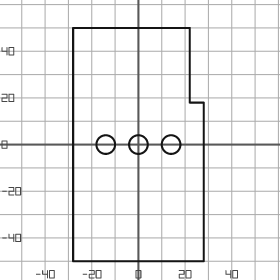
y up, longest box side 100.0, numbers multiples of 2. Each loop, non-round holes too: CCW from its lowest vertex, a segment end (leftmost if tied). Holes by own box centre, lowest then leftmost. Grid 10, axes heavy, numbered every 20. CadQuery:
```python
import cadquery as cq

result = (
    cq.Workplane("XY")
    .moveTo(-28.0, -50.0)
    .lineTo(28.0, -50.0)
    .lineTo(28.0, 18.0)
    .lineTo(22.0, 18.0)
    .lineTo(22.0, 50.0)
    .lineTo(-28.0, 50.0)
    .close()
    .moveTo(-14.0, 0.0)
    .circle(4.0)
    .moveTo(0.0, 0.0)
    .circle(4.0)
    .moveTo(14.0, 0.0)
    .circle(4.0)
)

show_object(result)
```